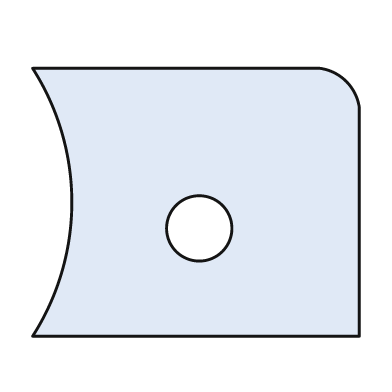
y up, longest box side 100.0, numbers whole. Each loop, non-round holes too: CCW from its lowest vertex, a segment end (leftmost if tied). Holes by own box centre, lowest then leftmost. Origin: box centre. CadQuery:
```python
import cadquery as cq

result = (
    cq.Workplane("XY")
    .moveTo(-50.0, -41.0)
    .lineTo(50.0, -41.0)
    .lineTo(50.0, 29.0)
    .threePointArc((46.0, 37.0), (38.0, 41.0))
    .lineTo(-50.0, 41.0)
    .threePointArc((-38.0, 0.0), (-50.0, -41.0))
    .close()
    .moveTo(1.0, -8.0)
    .circle(10.0)
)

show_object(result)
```